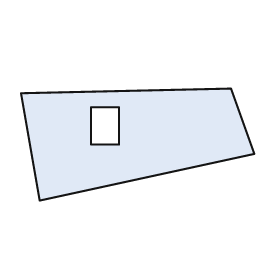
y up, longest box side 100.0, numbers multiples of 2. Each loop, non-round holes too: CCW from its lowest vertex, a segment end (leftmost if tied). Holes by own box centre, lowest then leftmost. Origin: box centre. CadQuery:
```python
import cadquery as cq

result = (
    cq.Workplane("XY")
    .moveTo(-42.0, -24.0)
    .lineTo(50.0, -4.0)
    .lineTo(40.0, 24.0)
    .lineTo(-50.0, 22.0)
    .close()
    .moveTo(-20.0, 0.0)
    .lineTo(-8.0, 0.0)
    .lineTo(-8.0, 16.0)
    .lineTo(-20.0, 16.0)
    .close()
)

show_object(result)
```